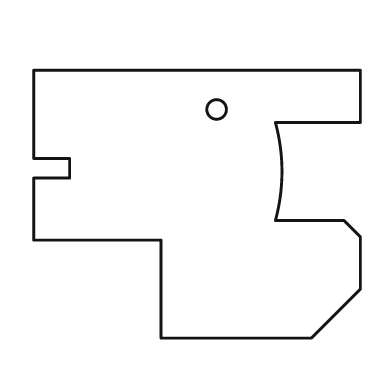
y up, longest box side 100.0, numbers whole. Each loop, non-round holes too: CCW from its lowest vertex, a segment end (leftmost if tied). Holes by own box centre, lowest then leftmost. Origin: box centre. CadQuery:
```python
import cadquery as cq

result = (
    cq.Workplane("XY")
    .moveTo(-11.0, -41.0)
    .lineTo(35.0, -41.0)
    .lineTo(50.0, -26.0)
    .lineTo(50.0, -10.0)
    .lineTo(45.0, -5.0)
    .lineTo(24.0, -5.0)
    .threePointArc((26.0, 10.0), (24.0, 25.0))
    .lineTo(50.0, 25.0)
    .lineTo(50.0, 41.0)
    .lineTo(-50.0, 41.0)
    .lineTo(-50.0, 14.0)
    .lineTo(-39.0, 14.0)
    .lineTo(-39.0, 8.0)
    .lineTo(-50.0, 8.0)
    .lineTo(-50.0, -11.0)
    .lineTo(-11.0, -11.0)
    .close()
    .moveTo(6.0, 29.0)
    .circle(3.0)
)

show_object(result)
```